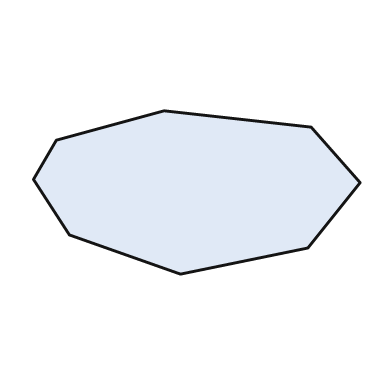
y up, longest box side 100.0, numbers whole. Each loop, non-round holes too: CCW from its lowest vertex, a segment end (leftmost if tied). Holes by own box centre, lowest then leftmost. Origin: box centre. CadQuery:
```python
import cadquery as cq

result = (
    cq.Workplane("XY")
    .moveTo(-5.0, -25.0)
    .lineTo(34.0, -17.0)
    .lineTo(50.0, 3.0)
    .lineTo(35.0, 20.0)
    .lineTo(-10.0, 25.0)
    .lineTo(-43.0, 16.0)
    .lineTo(-50.0, 4.0)
    .lineTo(-39.0, -13.0)
    .close()
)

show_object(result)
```